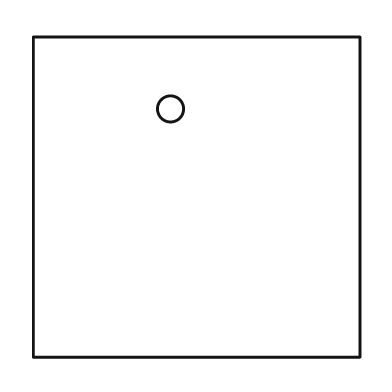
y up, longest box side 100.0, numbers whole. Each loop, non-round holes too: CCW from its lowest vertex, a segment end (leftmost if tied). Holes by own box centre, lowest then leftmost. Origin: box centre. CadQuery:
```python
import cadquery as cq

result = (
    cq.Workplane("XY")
    .moveTo(-50.0, -49.0)
    .lineTo(50.0, -49.0)
    .lineTo(50.0, 49.0)
    .lineTo(-50.0, 49.0)
    .close()
    .moveTo(-8.0, 27.0)
    .circle(4.0)
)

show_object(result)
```